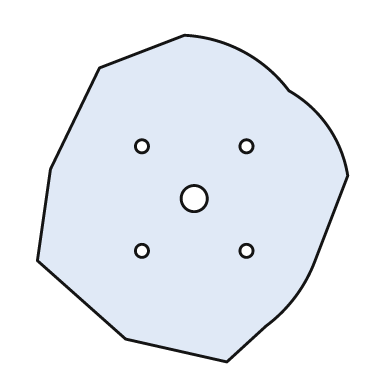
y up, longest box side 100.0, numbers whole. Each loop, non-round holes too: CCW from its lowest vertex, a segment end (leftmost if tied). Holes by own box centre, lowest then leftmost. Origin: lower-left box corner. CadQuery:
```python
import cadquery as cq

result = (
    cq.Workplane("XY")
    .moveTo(58.0, 0.0)
    .lineTo(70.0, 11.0)
    .threePointArc((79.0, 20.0), (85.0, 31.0))
    .lineTo(95.0, 57.0)
    .threePointArc((89.0, 72.0), (77.0, 83.0))
    .threePointArc((63.0, 95.0), (45.0, 100.0))
    .lineTo(19.0, 90.0)
    .lineTo(4.0, 59.0)
    .lineTo(0.0, 31.0)
    .lineTo(27.0, 7.0)
    .close()
    .moveTo(32.0, 34.0)
    .circle(2.0)
    .moveTo(64.0, 34.0)
    .circle(2.0)
    .moveTo(48.0, 50.0)
    .circle(4.0)
    .moveTo(32.0, 66.0)
    .circle(2.0)
    .moveTo(64.0, 66.0)
    .circle(2.0)
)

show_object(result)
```